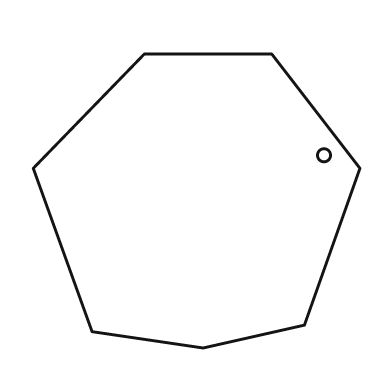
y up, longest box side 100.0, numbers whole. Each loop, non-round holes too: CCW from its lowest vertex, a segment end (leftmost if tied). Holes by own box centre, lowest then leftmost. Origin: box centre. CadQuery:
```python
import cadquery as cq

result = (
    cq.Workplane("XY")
    .moveTo(2.0, -45.0)
    .lineTo(33.0, -38.0)
    .lineTo(50.0, 10.0)
    .lineTo(23.0, 45.0)
    .lineTo(-16.0, 45.0)
    .lineTo(-50.0, 10.0)
    .lineTo(-32.0, -40.0)
    .close()
    .moveTo(39.0, 14.0)
    .circle(2.0)
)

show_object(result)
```